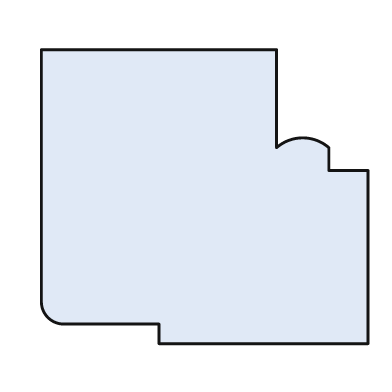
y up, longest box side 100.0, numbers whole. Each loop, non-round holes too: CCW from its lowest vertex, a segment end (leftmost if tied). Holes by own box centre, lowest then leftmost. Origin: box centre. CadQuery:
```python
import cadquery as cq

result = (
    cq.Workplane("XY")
    .moveTo(-14.0, -45.0)
    .lineTo(50.0, -45.0)
    .lineTo(50.0, 8.0)
    .lineTo(38.0, 8.0)
    .lineTo(38.0, 15.0)
    .threePointArc((30.0, 18.0), (22.0, 15.0))
    .lineTo(22.0, 45.0)
    .lineTo(-50.0, 45.0)
    .lineTo(-50.0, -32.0)
    .threePointArc((-48.0, -37.0), (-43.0, -39.0))
    .lineTo(-14.0, -39.0)
    .close()
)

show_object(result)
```